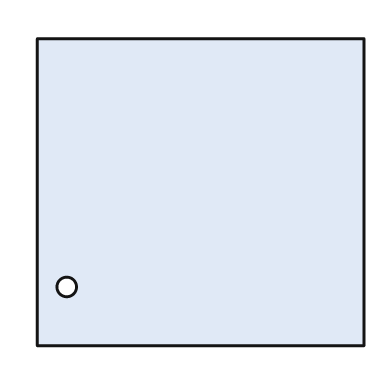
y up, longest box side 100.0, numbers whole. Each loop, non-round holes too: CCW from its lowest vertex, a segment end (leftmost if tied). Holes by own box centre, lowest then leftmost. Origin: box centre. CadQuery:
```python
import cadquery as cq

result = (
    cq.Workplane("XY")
    .moveTo(-50.0, -47.0)
    .lineTo(50.0, -47.0)
    .lineTo(50.0, 47.0)
    .lineTo(-50.0, 47.0)
    .close()
    .moveTo(-41.0, -29.0)
    .circle(3.0)
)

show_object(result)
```